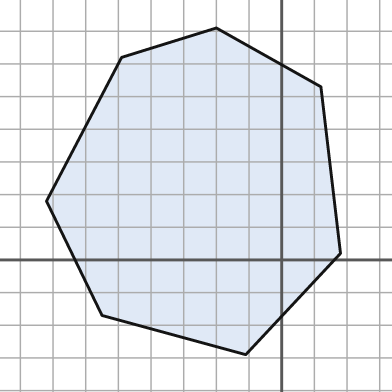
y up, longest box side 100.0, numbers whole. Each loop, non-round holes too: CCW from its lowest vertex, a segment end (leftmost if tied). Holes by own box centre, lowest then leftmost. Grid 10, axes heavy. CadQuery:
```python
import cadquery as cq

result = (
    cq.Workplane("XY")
    .moveTo(-11.0, -29.0)
    .lineTo(18.0, 2.0)
    .lineTo(12.0, 53.0)
    .lineTo(-20.0, 71.0)
    .lineTo(-49.0, 62.0)
    .lineTo(-72.0, 18.0)
    .lineTo(-55.0, -17.0)
    .close()
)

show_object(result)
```